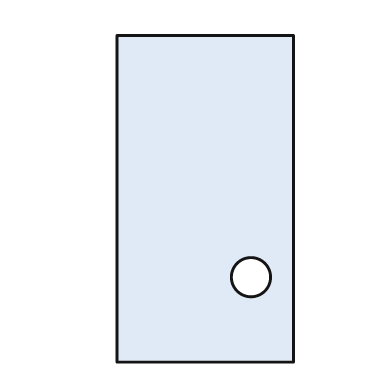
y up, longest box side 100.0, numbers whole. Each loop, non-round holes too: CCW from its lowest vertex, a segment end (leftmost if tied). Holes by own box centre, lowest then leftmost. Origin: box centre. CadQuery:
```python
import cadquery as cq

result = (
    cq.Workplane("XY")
    .moveTo(-27.0, -50.0)
    .lineTo(27.0, -50.0)
    .lineTo(27.0, 50.0)
    .lineTo(-27.0, 50.0)
    .close()
    .moveTo(14.0, -24.0)
    .circle(6.0)
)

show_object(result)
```